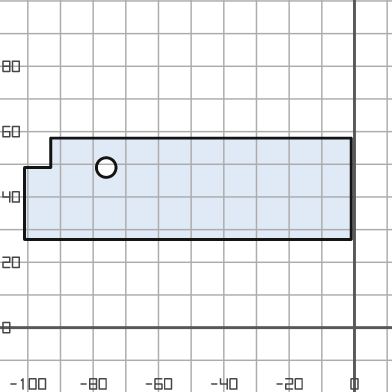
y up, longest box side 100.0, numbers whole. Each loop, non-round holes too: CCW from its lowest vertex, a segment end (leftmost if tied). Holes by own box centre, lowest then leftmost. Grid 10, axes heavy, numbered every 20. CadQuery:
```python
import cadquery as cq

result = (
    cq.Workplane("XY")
    .moveTo(-101.0, 27.0)
    .lineTo(-1.0, 27.0)
    .lineTo(-1.0, 58.0)
    .lineTo(-93.0, 58.0)
    .lineTo(-93.0, 49.0)
    .lineTo(-101.0, 49.0)
    .close()
    .moveTo(-76.0, 49.0)
    .circle(3.0)
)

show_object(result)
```